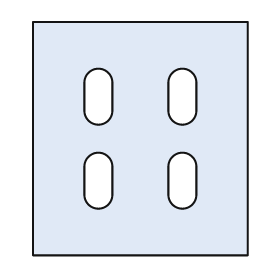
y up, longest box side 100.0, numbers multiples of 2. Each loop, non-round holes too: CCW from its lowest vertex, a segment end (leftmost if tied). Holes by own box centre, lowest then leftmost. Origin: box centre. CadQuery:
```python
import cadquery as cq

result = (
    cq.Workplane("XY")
    .moveTo(-46.0, -50.0)
    .lineTo(46.0, -50.0)
    .lineTo(46.0, 50.0)
    .lineTo(-46.0, 50.0)
    .close()
    .moveTo(-24.0, -24.0)
    .threePointArc((-18.0, -30.0), (-12.0, -24.0))
    .lineTo(-12.0, -12.0)
    .threePointArc((-18.0, -6.0), (-24.0, -12.0))
    .close()
    .moveTo(12.0, -24.0)
    .threePointArc((18.0, -30.0), (24.0, -24.0))
    .lineTo(24.0, -12.0)
    .threePointArc((18.0, -6.0), (12.0, -12.0))
    .close()
    .moveTo(-24.0, 12.0)
    .threePointArc((-18.0, 6.0), (-12.0, 12.0))
    .lineTo(-12.0, 24.0)
    .threePointArc((-18.0, 30.0), (-24.0, 24.0))
    .close()
    .moveTo(12.0, 12.0)
    .threePointArc((18.0, 6.0), (24.0, 12.0))
    .lineTo(24.0, 24.0)
    .threePointArc((18.0, 30.0), (12.0, 24.0))
    .close()
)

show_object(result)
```